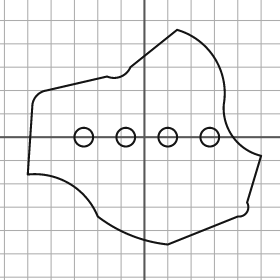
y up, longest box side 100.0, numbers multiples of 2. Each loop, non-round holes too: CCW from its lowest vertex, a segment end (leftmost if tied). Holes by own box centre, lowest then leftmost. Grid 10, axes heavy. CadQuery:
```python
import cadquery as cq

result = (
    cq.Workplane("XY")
    .moveTo(10.0, -46.0)
    .lineTo(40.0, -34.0)
    .threePointArc((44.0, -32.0), (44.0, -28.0))
    .lineTo(50.0, -8.0)
    .threePointArc((38.0, 0.0), (34.0, 14.0))
    .threePointArc((30.0, 34.0), (14.0, 46.0))
    .lineTo(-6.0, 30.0)
    .threePointArc((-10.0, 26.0), (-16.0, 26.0))
    .lineTo(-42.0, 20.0)
    .threePointArc((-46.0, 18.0), (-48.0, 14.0))
    .lineTo(-50.0, -16.0)
    .threePointArc((-32.0, -20.0), (-20.0, -34.0))
    .threePointArc((-6.0, -42.0), (10.0, -46.0))
    .close()
    .moveTo(-26.0, 0.0)
    .circle(4.0)
    .moveTo(-8.0, 0.0)
    .circle(4.0)
    .moveTo(10.0, 0.0)
    .circle(4.0)
    .moveTo(28.0, 0.0)
    .circle(4.0)
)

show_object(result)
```